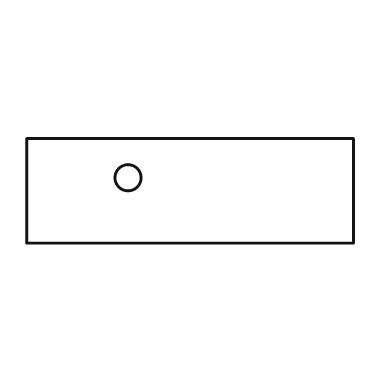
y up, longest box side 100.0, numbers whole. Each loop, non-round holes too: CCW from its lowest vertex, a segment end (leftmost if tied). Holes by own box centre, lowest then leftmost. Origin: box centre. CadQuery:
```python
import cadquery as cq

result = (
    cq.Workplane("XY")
    .moveTo(-50.0, -16.0)
    .lineTo(50.0, -16.0)
    .lineTo(50.0, 16.0)
    .lineTo(-50.0, 16.0)
    .close()
    .moveTo(-19.0, 4.0)
    .circle(4.0)
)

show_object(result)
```